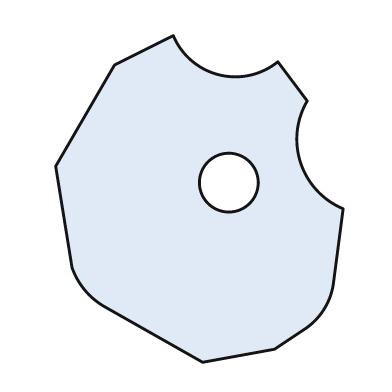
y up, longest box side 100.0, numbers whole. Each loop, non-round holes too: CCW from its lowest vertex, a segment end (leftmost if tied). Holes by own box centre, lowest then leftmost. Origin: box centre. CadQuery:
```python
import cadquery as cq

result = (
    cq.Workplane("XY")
    .moveTo(1.0, -50.0)
    .lineTo(23.0, -46.0)
    .lineTo(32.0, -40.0)
    .threePointArc((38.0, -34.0), (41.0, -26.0))
    .lineTo(44.0, -3.0)
    .threePointArc((31.0, 11.0), (33.0, 30.0))
    .lineTo(24.0, 42.0)
    .threePointArc((6.0, 38.0), (-8.0, 50.0))
    .lineTo(-26.0, 41.0)
    .lineTo(-44.0, 10.0)
    .lineTo(-39.0, -21.0)
    .threePointArc((-35.0, -28.0), (-29.0, -33.0))
    .close()
    .moveTo(9.0, 5.0)
    .circle(9.0)
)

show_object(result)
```